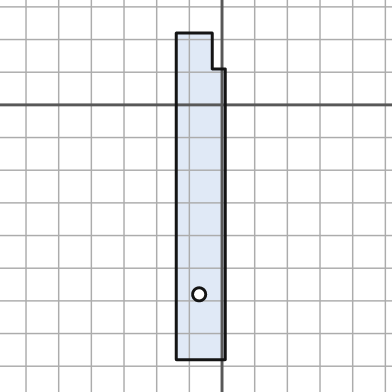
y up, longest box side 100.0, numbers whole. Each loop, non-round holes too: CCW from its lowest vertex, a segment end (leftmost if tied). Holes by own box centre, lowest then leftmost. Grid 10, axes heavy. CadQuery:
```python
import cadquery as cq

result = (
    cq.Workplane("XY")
    .moveTo(-14.0, -78.0)
    .lineTo(1.0, -78.0)
    .lineTo(1.0, 11.0)
    .lineTo(-3.0, 11.0)
    .lineTo(-3.0, 22.0)
    .lineTo(-14.0, 22.0)
    .close()
    .moveTo(-7.0, -58.0)
    .circle(2.0)
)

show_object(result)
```